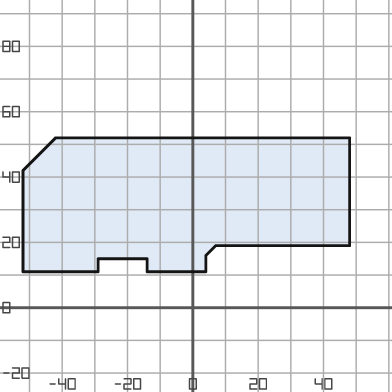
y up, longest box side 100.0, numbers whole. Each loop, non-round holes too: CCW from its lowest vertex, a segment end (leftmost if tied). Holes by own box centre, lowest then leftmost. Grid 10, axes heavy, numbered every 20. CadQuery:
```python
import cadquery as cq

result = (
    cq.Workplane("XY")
    .moveTo(-52.0, 11.0)
    .lineTo(-29.0, 11.0)
    .lineTo(-29.0, 15.0)
    .lineTo(-14.0, 15.0)
    .lineTo(-14.0, 11.0)
    .lineTo(4.0, 11.0)
    .lineTo(4.0, 16.0)
    .lineTo(7.0, 19.0)
    .lineTo(48.0, 19.0)
    .lineTo(48.0, 52.0)
    .lineTo(-42.0, 52.0)
    .lineTo(-52.0, 42.0)
    .close()
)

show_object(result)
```